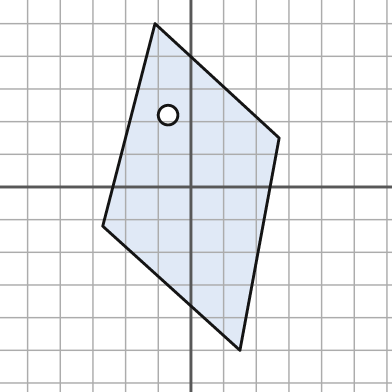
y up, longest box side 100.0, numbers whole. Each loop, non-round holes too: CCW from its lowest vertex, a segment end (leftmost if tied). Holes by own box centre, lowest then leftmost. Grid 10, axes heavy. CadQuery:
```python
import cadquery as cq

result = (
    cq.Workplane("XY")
    .moveTo(15.0, -50.0)
    .lineTo(27.0, 15.0)
    .lineTo(-11.0, 50.0)
    .lineTo(-27.0, -12.0)
    .close()
    .moveTo(-7.0, 22.0)
    .circle(3.0)
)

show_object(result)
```